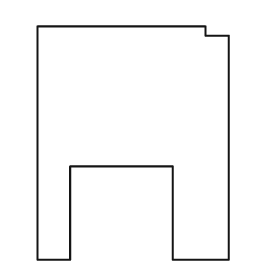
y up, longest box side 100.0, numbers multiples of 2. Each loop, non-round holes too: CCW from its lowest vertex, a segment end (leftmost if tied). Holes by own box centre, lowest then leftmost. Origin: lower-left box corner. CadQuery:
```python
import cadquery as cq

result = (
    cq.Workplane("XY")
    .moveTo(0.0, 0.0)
    .lineTo(14.0, 0.0)
    .lineTo(14.0, 40.0)
    .lineTo(58.0, 40.0)
    .lineTo(58.0, 0.0)
    .lineTo(82.0, 0.0)
    .lineTo(82.0, 96.0)
    .lineTo(72.0, 96.0)
    .lineTo(72.0, 100.0)
    .lineTo(0.0, 100.0)
    .close()
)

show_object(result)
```